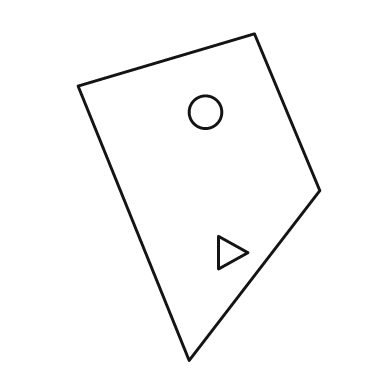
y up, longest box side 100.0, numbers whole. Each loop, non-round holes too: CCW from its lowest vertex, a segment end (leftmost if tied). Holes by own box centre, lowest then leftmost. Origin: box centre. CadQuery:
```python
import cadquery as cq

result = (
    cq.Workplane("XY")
    .moveTo(-3.0, -50.0)
    .lineTo(37.0, 2.0)
    .lineTo(17.0, 50.0)
    .lineTo(-37.0, 34.0)
    .close()
    .moveTo(6.0, -22.0)
    .lineTo(15.0, -17.0)
    .lineTo(6.0, -12.0)
    .close()
    .moveTo(2.0, 26.0)
    .circle(5.0)
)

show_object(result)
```